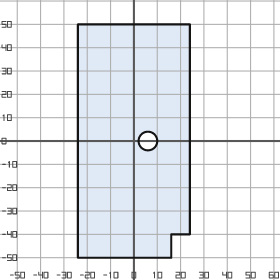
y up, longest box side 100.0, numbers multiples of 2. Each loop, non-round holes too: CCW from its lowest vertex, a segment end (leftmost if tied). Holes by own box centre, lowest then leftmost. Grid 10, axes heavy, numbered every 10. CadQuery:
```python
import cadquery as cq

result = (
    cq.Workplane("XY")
    .moveTo(-24.0, -50.0)
    .lineTo(16.0, -50.0)
    .lineTo(16.0, -40.0)
    .lineTo(24.0, -40.0)
    .lineTo(24.0, 50.0)
    .lineTo(-24.0, 50.0)
    .close()
    .moveTo(6.0, 0.0)
    .circle(4.0)
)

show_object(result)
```